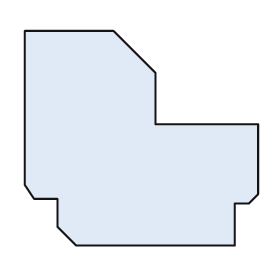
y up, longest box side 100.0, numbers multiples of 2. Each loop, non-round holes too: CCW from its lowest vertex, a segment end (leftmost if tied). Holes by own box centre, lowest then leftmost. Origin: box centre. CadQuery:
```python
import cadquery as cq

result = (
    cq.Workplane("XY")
    .moveTo(-28.0, -46.0)
    .lineTo(40.0, -46.0)
    .lineTo(40.0, -28.0)
    .lineTo(46.0, -28.0)
    .lineTo(50.0, -24.0)
    .lineTo(50.0, 6.0)
    .lineTo(6.0, 6.0)
    .lineTo(6.0, 28.0)
    .lineTo(-12.0, 46.0)
    .lineTo(-50.0, 46.0)
    .lineTo(-50.0, -20.0)
    .lineTo(-46.0, -26.0)
    .lineTo(-36.0, -26.0)
    .lineTo(-36.0, -38.0)
    .close()
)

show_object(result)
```